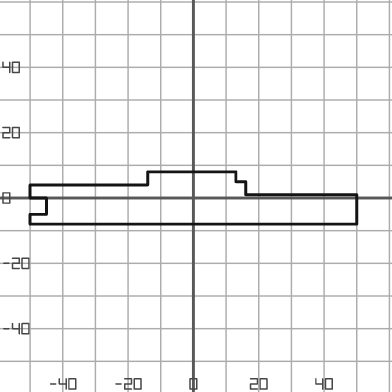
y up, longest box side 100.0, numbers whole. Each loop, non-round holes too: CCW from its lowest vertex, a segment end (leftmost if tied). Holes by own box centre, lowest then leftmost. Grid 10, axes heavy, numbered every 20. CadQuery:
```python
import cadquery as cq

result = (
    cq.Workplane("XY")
    .moveTo(-50.0, -8.0)
    .lineTo(50.0, -8.0)
    .lineTo(50.0, 1.0)
    .lineTo(16.0, 1.0)
    .lineTo(16.0, 5.0)
    .lineTo(13.0, 5.0)
    .lineTo(13.0, 8.0)
    .lineTo(-14.0, 8.0)
    .lineTo(-14.0, 4.0)
    .lineTo(-50.0, 4.0)
    .lineTo(-50.0, 0.0)
    .lineTo(-45.0, 0.0)
    .lineTo(-45.0, -5.0)
    .lineTo(-50.0, -5.0)
    .close()
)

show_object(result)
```